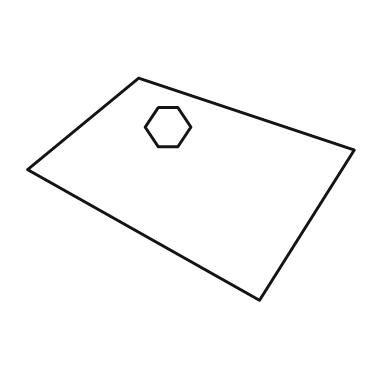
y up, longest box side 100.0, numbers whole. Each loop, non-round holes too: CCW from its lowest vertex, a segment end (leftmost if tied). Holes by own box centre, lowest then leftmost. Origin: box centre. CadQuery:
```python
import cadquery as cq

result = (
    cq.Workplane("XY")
    .moveTo(21.0, -34.0)
    .lineTo(50.0, 12.0)
    .lineTo(-16.0, 34.0)
    .lineTo(-50.0, 6.0)
    .close()
    .moveTo(-10.0, 13.0)
    .lineTo(-4.0, 13.0)
    .lineTo(0.0, 19.0)
    .lineTo(-4.0, 25.0)
    .lineTo(-10.0, 25.0)
    .lineTo(-14.0, 19.0)
    .close()
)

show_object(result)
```